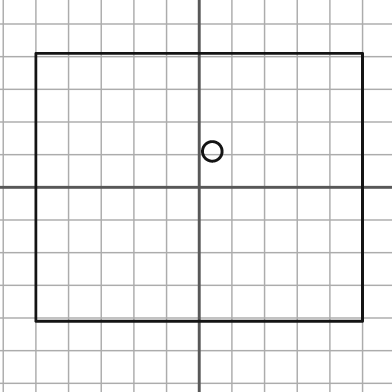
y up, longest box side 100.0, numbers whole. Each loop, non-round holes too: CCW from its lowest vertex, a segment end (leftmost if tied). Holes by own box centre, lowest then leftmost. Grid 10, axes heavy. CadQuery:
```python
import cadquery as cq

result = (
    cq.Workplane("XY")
    .moveTo(-50.0, -41.0)
    .lineTo(50.0, -41.0)
    .lineTo(50.0, 41.0)
    .lineTo(-50.0, 41.0)
    .close()
    .moveTo(4.0, 11.0)
    .circle(3.0)
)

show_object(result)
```